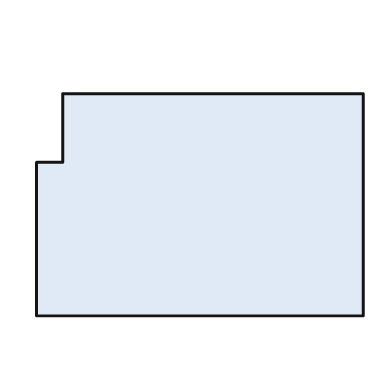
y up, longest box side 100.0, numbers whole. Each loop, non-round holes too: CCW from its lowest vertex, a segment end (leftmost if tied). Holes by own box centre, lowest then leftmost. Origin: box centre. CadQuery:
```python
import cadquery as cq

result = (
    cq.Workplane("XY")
    .moveTo(-50.0, -34.0)
    .lineTo(50.0, -34.0)
    .lineTo(50.0, 34.0)
    .lineTo(-42.0, 34.0)
    .lineTo(-42.0, 13.0)
    .lineTo(-50.0, 13.0)
    .close()
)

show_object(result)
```